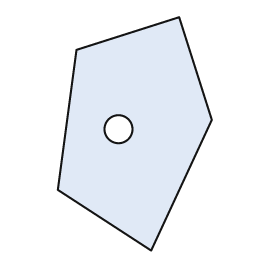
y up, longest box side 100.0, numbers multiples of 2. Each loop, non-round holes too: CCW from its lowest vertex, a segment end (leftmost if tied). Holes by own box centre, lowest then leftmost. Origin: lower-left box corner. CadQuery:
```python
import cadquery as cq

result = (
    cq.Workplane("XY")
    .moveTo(40.0, 0.0)
    .lineTo(66.0, 56.0)
    .lineTo(52.0, 100.0)
    .lineTo(8.0, 86.0)
    .lineTo(0.0, 26.0)
    .close()
    .moveTo(26.0, 52.0)
    .circle(6.0)
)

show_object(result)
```